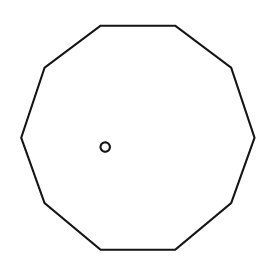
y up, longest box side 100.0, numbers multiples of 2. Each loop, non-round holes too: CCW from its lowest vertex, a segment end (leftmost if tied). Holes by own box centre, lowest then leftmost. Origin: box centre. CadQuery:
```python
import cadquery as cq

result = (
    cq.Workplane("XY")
    .moveTo(-16.0, -48.0)
    .lineTo(16.0, -48.0)
    .lineTo(40.0, -28.0)
    .lineTo(50.0, 0.0)
    .lineTo(40.0, 30.0)
    .lineTo(16.0, 48.0)
    .lineTo(-16.0, 48.0)
    .lineTo(-40.0, 30.0)
    .lineTo(-50.0, 0.0)
    .lineTo(-40.0, -28.0)
    .close()
    .moveTo(-14.0, -4.0)
    .circle(2.0)
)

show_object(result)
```